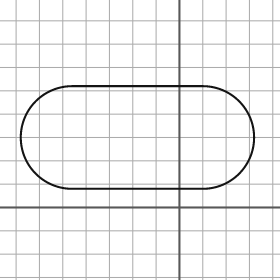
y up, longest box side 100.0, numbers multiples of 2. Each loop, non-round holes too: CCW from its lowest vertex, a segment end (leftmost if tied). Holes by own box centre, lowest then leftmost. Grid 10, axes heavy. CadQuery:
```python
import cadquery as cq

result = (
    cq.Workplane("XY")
    .moveTo(-46.0, 8.0)
    .lineTo(10.0, 8.0)
    .threePointArc((32.0, 30.0), (10.0, 52.0))
    .lineTo(-46.0, 52.0)
    .threePointArc((-68.0, 30.0), (-46.0, 8.0))
    .close()
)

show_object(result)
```